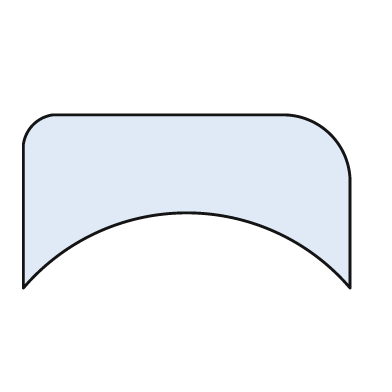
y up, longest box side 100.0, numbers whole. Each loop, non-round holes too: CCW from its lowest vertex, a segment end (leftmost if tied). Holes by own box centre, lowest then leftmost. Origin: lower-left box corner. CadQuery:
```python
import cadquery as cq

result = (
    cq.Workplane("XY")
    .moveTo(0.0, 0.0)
    .threePointArc((50.0, 23.0), (100.0, 0.0))
    .lineTo(100.0, 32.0)
    .threePointArc((94.0, 47.0), (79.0, 53.0))
    .lineTo(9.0, 53.0)
    .threePointArc((3.0, 50.0), (0.0, 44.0))
    .close()
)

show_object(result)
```